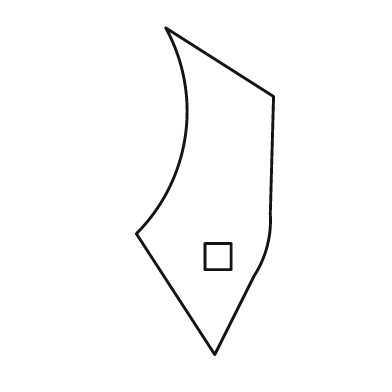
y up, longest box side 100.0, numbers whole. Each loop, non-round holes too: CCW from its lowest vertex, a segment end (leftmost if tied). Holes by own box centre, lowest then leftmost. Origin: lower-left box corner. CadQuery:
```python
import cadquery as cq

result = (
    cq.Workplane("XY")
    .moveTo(24.0, 0.0)
    .lineTo(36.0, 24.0)
    .threePointArc((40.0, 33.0), (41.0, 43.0))
    .lineTo(42.0, 79.0)
    .lineTo(9.0, 100.0)
    .threePointArc((15.0, 67.0), (0.0, 37.0))
    .close()
    .moveTo(21.0, 26.0)
    .lineTo(29.0, 26.0)
    .lineTo(29.0, 34.0)
    .lineTo(21.0, 34.0)
    .close()
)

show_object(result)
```